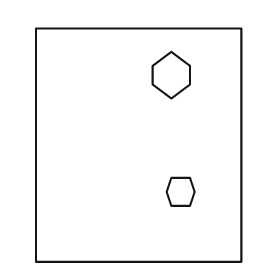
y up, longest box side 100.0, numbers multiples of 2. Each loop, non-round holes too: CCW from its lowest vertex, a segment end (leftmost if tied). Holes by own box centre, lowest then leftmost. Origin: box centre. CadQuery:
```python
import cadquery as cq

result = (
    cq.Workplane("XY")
    .moveTo(-44.0, -50.0)
    .lineTo(44.0, -50.0)
    .lineTo(44.0, 50.0)
    .lineTo(-44.0, 50.0)
    .close()
    .moveTo(14.0, -26.0)
    .lineTo(22.0, -26.0)
    .lineTo(24.0, -20.0)
    .lineTo(22.0, -14.0)
    .lineTo(14.0, -14.0)
    .lineTo(12.0, -20.0)
    .close()
    .moveTo(14.0, 20.0)
    .lineTo(22.0, 26.0)
    .lineTo(22.0, 34.0)
    .lineTo(14.0, 40.0)
    .lineTo(6.0, 34.0)
    .lineTo(6.0, 26.0)
    .close()
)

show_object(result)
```